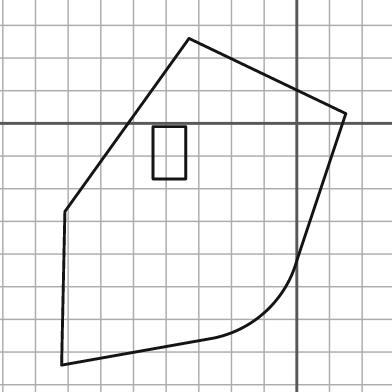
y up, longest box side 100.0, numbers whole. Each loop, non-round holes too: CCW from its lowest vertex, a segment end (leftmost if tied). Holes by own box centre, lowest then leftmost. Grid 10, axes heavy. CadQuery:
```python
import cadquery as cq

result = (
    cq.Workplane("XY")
    .moveTo(-72.0, -74.0)
    .lineTo(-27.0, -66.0)
    .threePointArc((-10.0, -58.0), (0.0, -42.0))
    .lineTo(15.0, 3.0)
    .lineTo(-33.0, 26.0)
    .lineTo(-71.0, -27.0)
    .close()
    .moveTo(-44.0, -17.0)
    .lineTo(-34.0, -17.0)
    .lineTo(-34.0, -1.0)
    .lineTo(-44.0, -1.0)
    .close()
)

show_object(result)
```